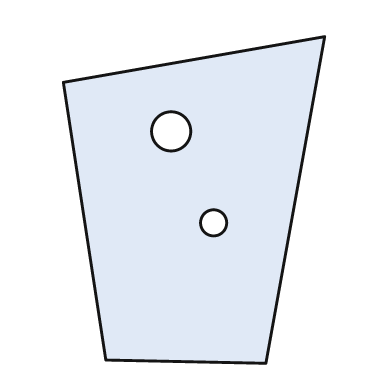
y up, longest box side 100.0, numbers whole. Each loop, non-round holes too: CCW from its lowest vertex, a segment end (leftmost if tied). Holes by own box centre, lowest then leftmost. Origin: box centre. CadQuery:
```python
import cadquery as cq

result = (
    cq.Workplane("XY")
    .moveTo(22.0, -50.0)
    .lineTo(40.0, 50.0)
    .lineTo(-40.0, 36.0)
    .lineTo(-27.0, -49.0)
    .close()
    .moveTo(6.0, -7.0)
    .circle(4.0)
    .moveTo(-7.0, 21.0)
    .circle(6.0)
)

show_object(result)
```